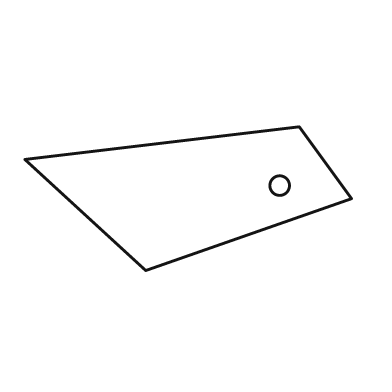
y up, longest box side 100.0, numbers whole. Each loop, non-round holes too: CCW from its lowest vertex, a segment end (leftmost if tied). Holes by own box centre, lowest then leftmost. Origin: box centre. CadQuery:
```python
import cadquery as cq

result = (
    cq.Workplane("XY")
    .moveTo(-13.0, -22.0)
    .lineTo(50.0, 0.0)
    .lineTo(34.0, 22.0)
    .lineTo(-50.0, 12.0)
    .close()
    .moveTo(28.0, 4.0)
    .circle(3.0)
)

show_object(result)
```